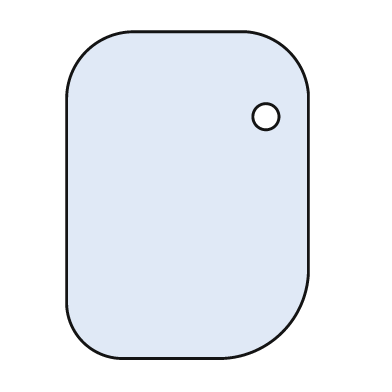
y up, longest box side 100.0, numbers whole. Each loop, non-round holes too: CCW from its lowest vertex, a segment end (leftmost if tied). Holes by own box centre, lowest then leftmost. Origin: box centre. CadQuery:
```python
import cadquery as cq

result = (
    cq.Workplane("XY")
    .moveTo(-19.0, -50.0)
    .lineTo(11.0, -50.0)
    .threePointArc((29.0, -42.0), (37.0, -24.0))
    .lineTo(37.0, 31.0)
    .threePointArc((31.0, 44.0), (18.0, 50.0))
    .lineTo(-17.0, 50.0)
    .threePointArc((-31.0, 44.0), (-37.0, 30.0))
    .lineTo(-37.0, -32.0)
    .threePointArc((-32.0, -45.0), (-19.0, -50.0))
    .close()
    .moveTo(24.0, 24.0)
    .circle(4.0)
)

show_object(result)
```